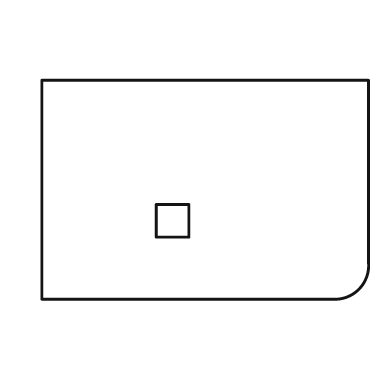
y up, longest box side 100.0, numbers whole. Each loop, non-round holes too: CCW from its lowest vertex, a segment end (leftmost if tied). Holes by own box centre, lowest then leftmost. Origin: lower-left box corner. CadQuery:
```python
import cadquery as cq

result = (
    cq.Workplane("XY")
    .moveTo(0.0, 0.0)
    .lineTo(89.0, 0.0)
    .threePointArc((97.0, 3.0), (100.0, 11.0))
    .lineTo(100.0, 67.0)
    .lineTo(0.0, 67.0)
    .close()
    .moveTo(35.0, 19.0)
    .lineTo(45.0, 19.0)
    .lineTo(45.0, 29.0)
    .lineTo(35.0, 29.0)
    .close()
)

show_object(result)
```